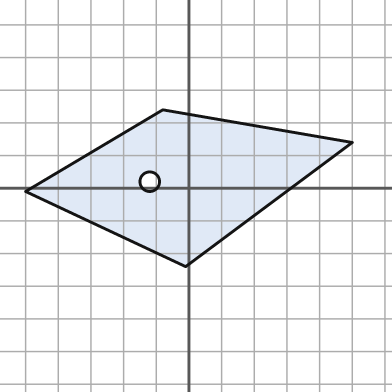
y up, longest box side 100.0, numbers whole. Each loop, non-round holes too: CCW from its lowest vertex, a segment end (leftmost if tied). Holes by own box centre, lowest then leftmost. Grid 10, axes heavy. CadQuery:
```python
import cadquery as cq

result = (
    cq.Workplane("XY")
    .moveTo(-1.0, -24.0)
    .lineTo(50.0, 14.0)
    .lineTo(-8.0, 24.0)
    .lineTo(-50.0, -1.0)
    .close()
    .moveTo(-12.0, 2.0)
    .circle(3.0)
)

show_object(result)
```